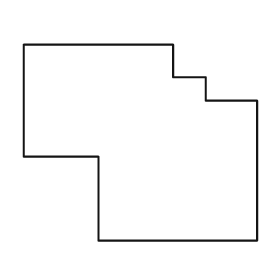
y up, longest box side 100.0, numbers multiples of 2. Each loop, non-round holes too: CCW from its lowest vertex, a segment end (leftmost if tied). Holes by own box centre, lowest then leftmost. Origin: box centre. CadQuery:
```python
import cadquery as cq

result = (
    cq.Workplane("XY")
    .moveTo(-18.0, -42.0)
    .lineTo(50.0, -42.0)
    .lineTo(50.0, 18.0)
    .lineTo(28.0, 18.0)
    .lineTo(28.0, 28.0)
    .lineTo(14.0, 28.0)
    .lineTo(14.0, 42.0)
    .lineTo(-50.0, 42.0)
    .lineTo(-50.0, -6.0)
    .lineTo(-18.0, -6.0)
    .close()
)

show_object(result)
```